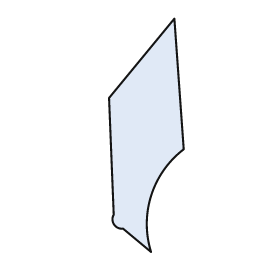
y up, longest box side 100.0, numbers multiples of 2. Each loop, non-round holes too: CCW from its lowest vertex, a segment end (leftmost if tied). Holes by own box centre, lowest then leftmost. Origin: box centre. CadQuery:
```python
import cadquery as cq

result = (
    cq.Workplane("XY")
    .moveTo(2.0, -50.0)
    .threePointArc((2.0, -26.0), (16.0, -6.0))
    .lineTo(12.0, 50.0)
    .lineTo(-16.0, 16.0)
    .lineTo(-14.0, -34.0)
    .threePointArc((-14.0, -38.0), (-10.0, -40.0))
    .close()
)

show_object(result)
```